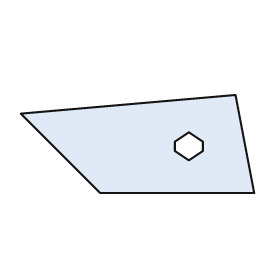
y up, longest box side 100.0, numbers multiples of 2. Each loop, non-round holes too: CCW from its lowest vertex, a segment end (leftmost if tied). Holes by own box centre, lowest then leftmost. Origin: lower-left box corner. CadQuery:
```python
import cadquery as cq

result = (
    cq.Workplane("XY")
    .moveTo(34.0, 0.0)
    .lineTo(100.0, 0.0)
    .lineTo(92.0, 42.0)
    .lineTo(0.0, 34.0)
    .close()
    .moveTo(72.0, 14.0)
    .lineTo(78.0, 18.0)
    .lineTo(78.0, 22.0)
    .lineTo(72.0, 26.0)
    .lineTo(66.0, 22.0)
    .lineTo(66.0, 18.0)
    .close()
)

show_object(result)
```